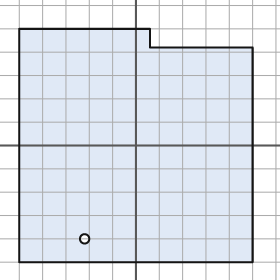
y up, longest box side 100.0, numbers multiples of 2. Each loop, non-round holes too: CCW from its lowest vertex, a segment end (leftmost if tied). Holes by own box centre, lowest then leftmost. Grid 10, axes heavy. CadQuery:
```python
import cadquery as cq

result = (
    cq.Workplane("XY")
    .moveTo(-50.0, -50.0)
    .lineTo(50.0, -50.0)
    .lineTo(50.0, 42.0)
    .lineTo(6.0, 42.0)
    .lineTo(6.0, 50.0)
    .lineTo(-50.0, 50.0)
    .close()
    .moveTo(-22.0, -40.0)
    .circle(2.0)
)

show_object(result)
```